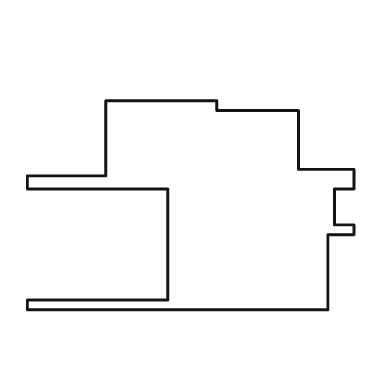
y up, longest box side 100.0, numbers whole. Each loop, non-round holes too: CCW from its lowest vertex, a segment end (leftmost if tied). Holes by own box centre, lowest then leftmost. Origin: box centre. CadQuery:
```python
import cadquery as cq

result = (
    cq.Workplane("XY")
    .moveTo(-50.0, -32.0)
    .lineTo(42.0, -32.0)
    .lineTo(42.0, -9.0)
    .lineTo(50.0, -9.0)
    .lineTo(50.0, -6.0)
    .lineTo(44.0, -6.0)
    .lineTo(44.0, 5.0)
    .lineTo(50.0, 5.0)
    .lineTo(50.0, 11.0)
    .lineTo(33.0, 11.0)
    .lineTo(33.0, 29.0)
    .lineTo(8.0, 29.0)
    .lineTo(8.0, 32.0)
    .lineTo(-26.0, 32.0)
    .lineTo(-26.0, 9.0)
    .lineTo(-50.0, 9.0)
    .lineTo(-50.0, 5.0)
    .lineTo(-7.0, 5.0)
    .lineTo(-7.0, -29.0)
    .lineTo(-50.0, -29.0)
    .close()
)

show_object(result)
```